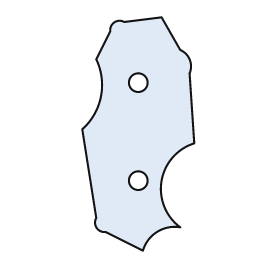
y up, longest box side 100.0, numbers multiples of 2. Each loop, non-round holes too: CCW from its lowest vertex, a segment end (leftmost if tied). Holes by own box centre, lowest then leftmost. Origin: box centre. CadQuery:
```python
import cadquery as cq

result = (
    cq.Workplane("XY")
    .moveTo(2.0, -50.0)
    .threePointArc((8.0, -42.0), (18.0, -40.0))
    .threePointArc((10.0, -20.0), (24.0, -4.0))
    .lineTo(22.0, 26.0)
    .threePointArc((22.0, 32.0), (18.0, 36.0))
    .lineTo(10.0, 50.0)
    .lineTo(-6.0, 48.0)
    .threePointArc((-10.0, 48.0), (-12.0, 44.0))
    .lineTo(-18.0, 32.0)
    .threePointArc((-16.0, 16.0), (-24.0, 2.0))
    .lineTo(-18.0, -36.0)
    .threePointArc((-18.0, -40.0), (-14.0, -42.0))
    .close()
    .moveTo(0.0, -20.0)
    .circle(4.0)
    .moveTo(0.0, 22.0)
    .circle(4.0)
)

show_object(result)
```